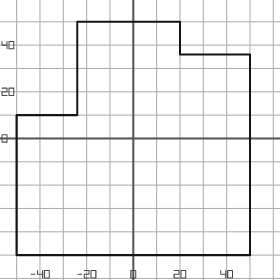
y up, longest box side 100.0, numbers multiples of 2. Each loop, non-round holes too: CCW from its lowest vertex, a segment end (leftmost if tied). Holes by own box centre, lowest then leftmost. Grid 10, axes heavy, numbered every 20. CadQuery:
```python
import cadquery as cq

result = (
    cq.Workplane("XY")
    .moveTo(-50.0, -50.0)
    .lineTo(50.0, -50.0)
    .lineTo(50.0, 36.0)
    .lineTo(20.0, 36.0)
    .lineTo(20.0, 50.0)
    .lineTo(-24.0, 50.0)
    .lineTo(-24.0, 10.0)
    .lineTo(-50.0, 10.0)
    .close()
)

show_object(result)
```